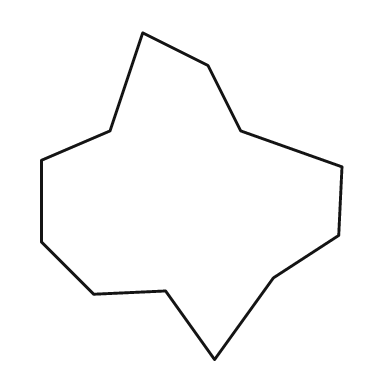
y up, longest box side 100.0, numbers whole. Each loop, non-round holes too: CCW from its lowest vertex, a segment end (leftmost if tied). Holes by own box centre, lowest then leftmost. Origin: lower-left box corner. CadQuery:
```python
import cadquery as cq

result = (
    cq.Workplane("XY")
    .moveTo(53.0, 0.0)
    .lineTo(71.0, 25.0)
    .lineTo(91.0, 38.0)
    .lineTo(92.0, 59.0)
    .lineTo(61.0, 70.0)
    .lineTo(51.0, 90.0)
    .lineTo(31.0, 100.0)
    .lineTo(21.0, 70.0)
    .lineTo(0.0, 61.0)
    .lineTo(0.0, 36.0)
    .lineTo(16.0, 20.0)
    .lineTo(38.0, 21.0)
    .close()
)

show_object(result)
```